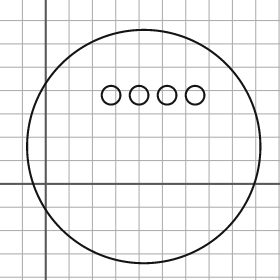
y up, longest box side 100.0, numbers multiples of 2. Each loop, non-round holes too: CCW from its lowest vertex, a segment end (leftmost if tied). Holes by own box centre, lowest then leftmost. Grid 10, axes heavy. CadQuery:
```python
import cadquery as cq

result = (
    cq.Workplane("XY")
    .moveTo(42.0, 16.0)
    .circle(50.0)
    .moveTo(28.0, 38.0)
    .circle(4.0)
    .moveTo(40.0, 38.0)
    .circle(4.0)
    .moveTo(52.0, 38.0)
    .circle(4.0)
    .moveTo(64.0, 38.0)
    .circle(4.0)
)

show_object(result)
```